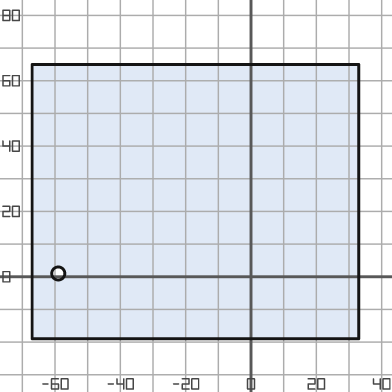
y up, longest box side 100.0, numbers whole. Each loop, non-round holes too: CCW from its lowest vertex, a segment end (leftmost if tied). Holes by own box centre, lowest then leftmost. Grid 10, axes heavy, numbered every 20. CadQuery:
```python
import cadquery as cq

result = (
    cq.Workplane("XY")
    .moveTo(-67.0, -19.0)
    .lineTo(33.0, -19.0)
    .lineTo(33.0, 65.0)
    .lineTo(-67.0, 65.0)
    .close()
    .moveTo(-59.0, 1.0)
    .circle(2.0)
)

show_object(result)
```